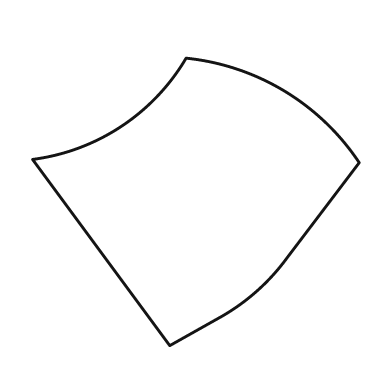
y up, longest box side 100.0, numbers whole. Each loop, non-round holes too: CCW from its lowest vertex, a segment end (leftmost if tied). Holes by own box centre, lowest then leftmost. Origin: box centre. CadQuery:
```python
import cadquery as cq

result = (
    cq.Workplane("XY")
    .moveTo(-8.0, -44.0)
    .lineTo(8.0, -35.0)
    .threePointArc((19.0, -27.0), (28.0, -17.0))
    .lineTo(50.0, 12.0)
    .threePointArc((27.0, 34.0), (-3.0, 44.0))
    .threePointArc((-23.0, 23.0), (-50.0, 13.0))
    .close()
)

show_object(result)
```